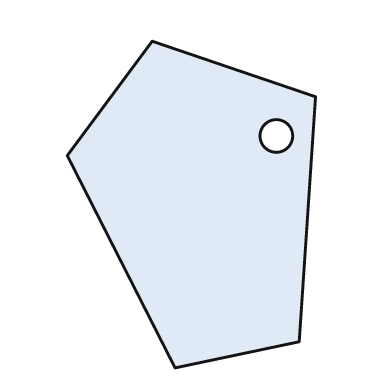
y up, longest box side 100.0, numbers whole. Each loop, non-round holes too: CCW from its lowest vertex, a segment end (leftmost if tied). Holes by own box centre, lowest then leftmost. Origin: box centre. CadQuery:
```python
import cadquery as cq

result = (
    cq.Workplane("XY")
    .moveTo(-5.0, -50.0)
    .lineTo(33.0, -42.0)
    .lineTo(38.0, 33.0)
    .lineTo(-12.0, 50.0)
    .lineTo(-38.0, 15.0)
    .close()
    .moveTo(26.0, 21.0)
    .circle(5.0)
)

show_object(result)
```